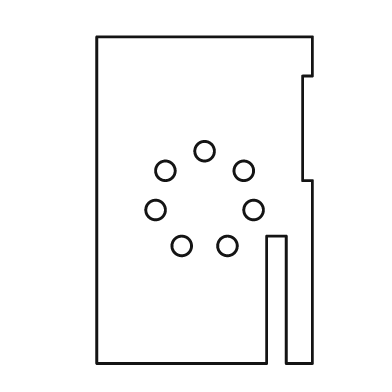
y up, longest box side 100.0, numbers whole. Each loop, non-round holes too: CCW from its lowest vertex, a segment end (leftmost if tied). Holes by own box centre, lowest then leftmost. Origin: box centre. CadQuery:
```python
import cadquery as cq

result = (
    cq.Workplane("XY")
    .moveTo(-33.0, -50.0)
    .lineTo(19.0, -50.0)
    .lineTo(19.0, -11.0)
    .lineTo(25.0, -11.0)
    .lineTo(25.0, -50.0)
    .lineTo(33.0, -50.0)
    .lineTo(33.0, 6.0)
    .lineTo(30.0, 6.0)
    .lineTo(30.0, 38.0)
    .lineTo(33.0, 38.0)
    .lineTo(33.0, 50.0)
    .lineTo(-33.0, 50.0)
    .close()
    .moveTo(-7.0, -14.0)
    .circle(3.0)
    .moveTo(7.0, -14.0)
    .circle(3.0)
    .moveTo(-15.0, -3.0)
    .circle(3.0)
    .moveTo(15.0, -3.0)
    .circle(3.0)
    .moveTo(-12.0, 9.0)
    .circle(3.0)
    .moveTo(12.0, 9.0)
    .circle(3.0)
    .moveTo(0.0, 15.0)
    .circle(3.0)
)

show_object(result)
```